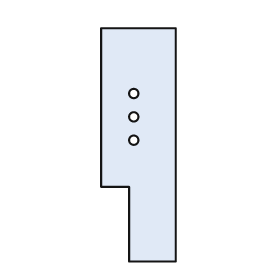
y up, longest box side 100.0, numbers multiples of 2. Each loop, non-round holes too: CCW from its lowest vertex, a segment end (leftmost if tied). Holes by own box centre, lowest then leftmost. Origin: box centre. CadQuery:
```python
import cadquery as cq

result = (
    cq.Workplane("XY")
    .moveTo(-4.0, -50.0)
    .lineTo(16.0, -50.0)
    .lineTo(16.0, 50.0)
    .lineTo(-16.0, 50.0)
    .lineTo(-16.0, -18.0)
    .lineTo(-4.0, -18.0)
    .close()
    .moveTo(-2.0, 2.0)
    .circle(2.0)
    .moveTo(-2.0, 12.0)
    .circle(2.0)
    .moveTo(-2.0, 22.0)
    .circle(2.0)
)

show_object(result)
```